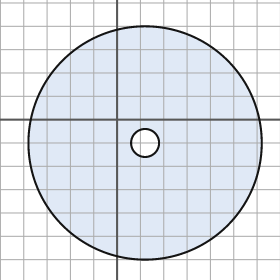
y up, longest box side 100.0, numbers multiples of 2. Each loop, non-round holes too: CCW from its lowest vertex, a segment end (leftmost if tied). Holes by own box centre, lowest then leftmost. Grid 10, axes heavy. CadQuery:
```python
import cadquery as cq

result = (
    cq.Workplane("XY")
    .moveTo(12.0, -10.0)
    .circle(50.0)
    .moveTo(12.0, -10.0)
    .circle(6.0)
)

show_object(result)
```